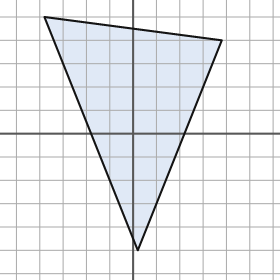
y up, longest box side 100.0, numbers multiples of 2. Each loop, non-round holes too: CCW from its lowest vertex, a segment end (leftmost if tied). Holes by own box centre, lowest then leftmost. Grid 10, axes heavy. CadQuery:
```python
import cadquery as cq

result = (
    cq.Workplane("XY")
    .moveTo(2.0, -50.0)
    .lineTo(38.0, 40.0)
    .lineTo(-38.0, 50.0)
    .close()
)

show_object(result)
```